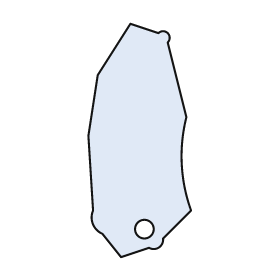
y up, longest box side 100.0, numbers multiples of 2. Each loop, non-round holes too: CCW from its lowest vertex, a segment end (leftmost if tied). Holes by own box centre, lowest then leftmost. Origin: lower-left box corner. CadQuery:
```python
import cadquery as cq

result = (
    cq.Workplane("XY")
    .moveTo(14.0, 0.0)
    .lineTo(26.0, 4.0)
    .threePointArc((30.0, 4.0), (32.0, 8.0))
    .lineTo(44.0, 20.0)
    .threePointArc((40.0, 40.0), (42.0, 60.0))
    .lineTo(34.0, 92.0)
    .threePointArc((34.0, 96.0), (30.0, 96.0))
    .lineTo(18.0, 100.0)
    .lineTo(4.0, 78.0)
    .lineTo(0.0, 52.0)
    .lineTo(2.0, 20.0)
    .threePointArc((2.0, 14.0), (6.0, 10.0))
    .close()
    .moveTo(24.0, 12.0)
    .circle(4.0)
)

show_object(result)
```